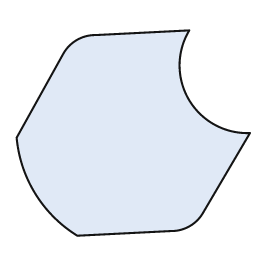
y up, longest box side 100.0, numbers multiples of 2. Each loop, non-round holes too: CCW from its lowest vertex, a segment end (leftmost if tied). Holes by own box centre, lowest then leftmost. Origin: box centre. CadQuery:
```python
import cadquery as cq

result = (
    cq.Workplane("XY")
    .moveTo(-24.0, -44.0)
    .lineTo(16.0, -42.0)
    .threePointArc((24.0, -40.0), (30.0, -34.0))
    .lineTo(50.0, 0.0)
    .threePointArc((24.0, 14.0), (24.0, 44.0))
    .lineTo(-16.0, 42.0)
    .threePointArc((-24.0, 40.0), (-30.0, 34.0))
    .lineTo(-50.0, -2.0)
    .threePointArc((-42.0, -26.0), (-24.0, -44.0))
    .close()
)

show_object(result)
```